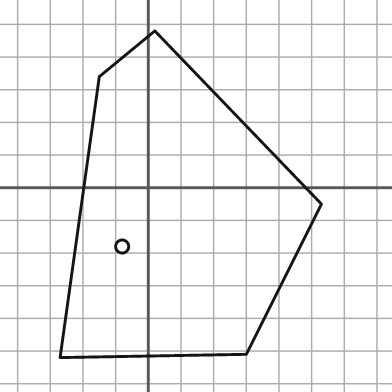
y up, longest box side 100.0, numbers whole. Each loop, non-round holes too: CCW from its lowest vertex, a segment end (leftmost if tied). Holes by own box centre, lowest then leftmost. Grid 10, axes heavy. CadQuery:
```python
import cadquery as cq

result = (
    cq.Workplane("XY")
    .moveTo(-27.0, -52.0)
    .lineTo(30.0, -51.0)
    .lineTo(53.0, -5.0)
    .lineTo(2.0, 48.0)
    .lineTo(-15.0, 34.0)
    .close()
    .moveTo(-8.0, -18.0)
    .circle(2.0)
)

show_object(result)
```